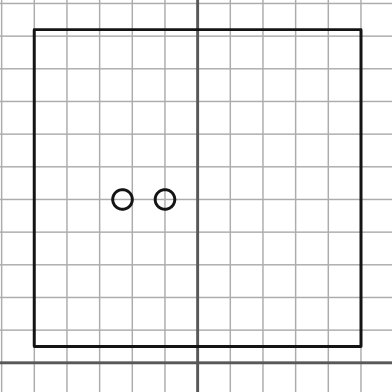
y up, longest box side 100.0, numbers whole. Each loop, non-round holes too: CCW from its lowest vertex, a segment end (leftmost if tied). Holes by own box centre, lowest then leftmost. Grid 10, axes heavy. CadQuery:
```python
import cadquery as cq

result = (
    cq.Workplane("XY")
    .moveTo(-50.0, 5.0)
    .lineTo(50.0, 5.0)
    .lineTo(50.0, 102.0)
    .lineTo(-50.0, 102.0)
    .close()
    .moveTo(-23.0, 50.0)
    .circle(3.0)
    .moveTo(-10.0, 50.0)
    .circle(3.0)
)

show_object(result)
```